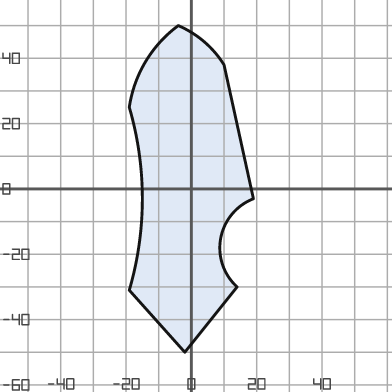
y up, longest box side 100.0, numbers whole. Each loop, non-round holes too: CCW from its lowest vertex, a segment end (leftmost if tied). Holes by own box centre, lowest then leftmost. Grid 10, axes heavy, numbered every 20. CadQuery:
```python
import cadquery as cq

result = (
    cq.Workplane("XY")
    .moveTo(-2.0, -50.0)
    .lineTo(14.0, -30.0)
    .threePointArc((9.0, -15.0), (19.0, -3.0))
    .lineTo(10.0, 38.0)
    .threePointArc((4.0, 45.0), (-4.0, 50.0))
    .threePointArc((-14.0, 39.0), (-19.0, 25.0))
    .threePointArc((-15.0, -3.0), (-19.0, -31.0))
    .close()
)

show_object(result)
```